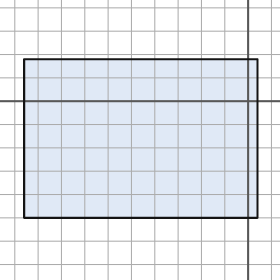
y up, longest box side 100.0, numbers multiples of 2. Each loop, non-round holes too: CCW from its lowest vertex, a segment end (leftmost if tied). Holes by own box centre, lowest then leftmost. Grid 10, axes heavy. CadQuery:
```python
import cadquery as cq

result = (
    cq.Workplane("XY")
    .moveTo(-96.0, -50.0)
    .lineTo(4.0, -50.0)
    .lineTo(4.0, 18.0)
    .lineTo(-96.0, 18.0)
    .close()
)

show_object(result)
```